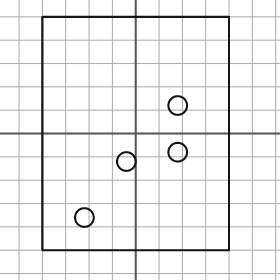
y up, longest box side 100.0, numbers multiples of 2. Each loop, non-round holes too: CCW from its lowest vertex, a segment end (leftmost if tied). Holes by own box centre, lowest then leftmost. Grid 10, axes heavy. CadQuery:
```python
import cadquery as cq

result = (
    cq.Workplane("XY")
    .moveTo(-40.0, -50.0)
    .lineTo(40.0, -50.0)
    .lineTo(40.0, 50.0)
    .lineTo(-40.0, 50.0)
    .close()
    .moveTo(-22.0, -36.0)
    .circle(4.0)
    .moveTo(-4.0, -12.0)
    .circle(4.0)
    .moveTo(18.0, -8.0)
    .circle(4.0)
    .moveTo(18.0, 12.0)
    .circle(4.0)
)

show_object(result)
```